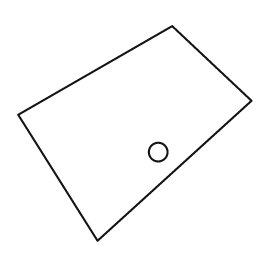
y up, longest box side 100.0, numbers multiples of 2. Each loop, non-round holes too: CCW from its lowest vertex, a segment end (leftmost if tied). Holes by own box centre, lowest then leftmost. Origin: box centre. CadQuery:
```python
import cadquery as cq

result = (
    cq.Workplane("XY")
    .moveTo(-16.0, -46.0)
    .lineTo(50.0, 14.0)
    .lineTo(16.0, 46.0)
    .lineTo(-50.0, 8.0)
    .close()
    .moveTo(10.0, -8.0)
    .circle(4.0)
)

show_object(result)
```